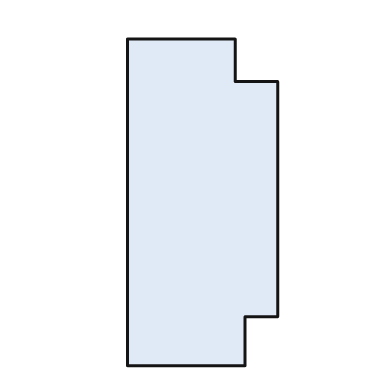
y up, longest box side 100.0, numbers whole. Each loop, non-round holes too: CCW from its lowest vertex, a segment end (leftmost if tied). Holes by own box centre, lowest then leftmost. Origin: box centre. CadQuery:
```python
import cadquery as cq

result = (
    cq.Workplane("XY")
    .moveTo(-23.0, -50.0)
    .lineTo(13.0, -50.0)
    .lineTo(13.0, -35.0)
    .lineTo(23.0, -35.0)
    .lineTo(23.0, 37.0)
    .lineTo(10.0, 37.0)
    .lineTo(10.0, 50.0)
    .lineTo(-23.0, 50.0)
    .close()
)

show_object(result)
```